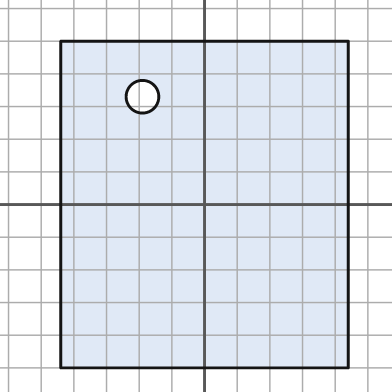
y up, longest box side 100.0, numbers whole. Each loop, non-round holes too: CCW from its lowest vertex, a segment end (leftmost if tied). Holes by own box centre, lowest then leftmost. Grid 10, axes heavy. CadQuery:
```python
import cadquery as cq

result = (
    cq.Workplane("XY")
    .moveTo(-44.0, -50.0)
    .lineTo(44.0, -50.0)
    .lineTo(44.0, 50.0)
    .lineTo(-44.0, 50.0)
    .close()
    .moveTo(-19.0, 33.0)
    .circle(5.0)
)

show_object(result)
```